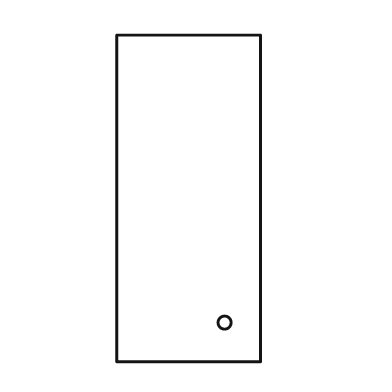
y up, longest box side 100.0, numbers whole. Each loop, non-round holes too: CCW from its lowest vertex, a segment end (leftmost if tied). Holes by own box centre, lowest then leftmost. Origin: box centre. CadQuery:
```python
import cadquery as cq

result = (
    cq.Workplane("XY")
    .moveTo(-22.0, -50.0)
    .lineTo(22.0, -50.0)
    .lineTo(22.0, 50.0)
    .lineTo(-22.0, 50.0)
    .close()
    .moveTo(11.0, -38.0)
    .circle(2.0)
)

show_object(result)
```